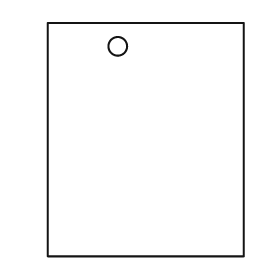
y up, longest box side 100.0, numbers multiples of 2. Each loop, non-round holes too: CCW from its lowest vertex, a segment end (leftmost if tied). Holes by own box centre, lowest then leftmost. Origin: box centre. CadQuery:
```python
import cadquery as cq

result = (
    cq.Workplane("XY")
    .moveTo(-42.0, -50.0)
    .lineTo(42.0, -50.0)
    .lineTo(42.0, 50.0)
    .lineTo(-42.0, 50.0)
    .close()
    .moveTo(-12.0, 40.0)
    .circle(4.0)
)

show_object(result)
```